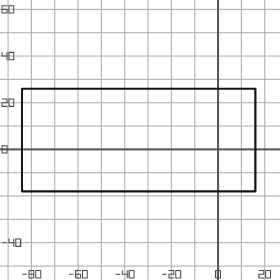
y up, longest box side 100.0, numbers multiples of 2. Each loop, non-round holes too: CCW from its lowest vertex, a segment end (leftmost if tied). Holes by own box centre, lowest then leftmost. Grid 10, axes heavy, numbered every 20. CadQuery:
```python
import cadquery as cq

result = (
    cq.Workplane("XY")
    .moveTo(-84.0, -18.0)
    .lineTo(16.0, -18.0)
    .lineTo(16.0, 26.0)
    .lineTo(-84.0, 26.0)
    .close()
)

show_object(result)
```